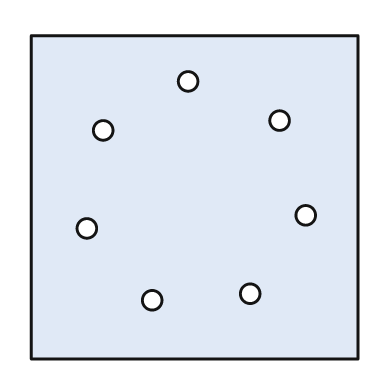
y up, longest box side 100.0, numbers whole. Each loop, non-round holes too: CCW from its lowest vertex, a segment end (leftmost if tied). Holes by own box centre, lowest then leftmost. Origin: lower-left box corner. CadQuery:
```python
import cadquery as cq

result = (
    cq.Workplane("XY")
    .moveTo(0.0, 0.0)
    .lineTo(100.0, 0.0)
    .lineTo(100.0, 99.0)
    .lineTo(0.0, 99.0)
    .close()
    .moveTo(37.0, 18.0)
    .circle(3.0)
    .moveTo(67.0, 20.0)
    .circle(3.0)
    .moveTo(17.0, 40.0)
    .circle(3.0)
    .moveTo(84.0, 44.0)
    .circle(3.0)
    .moveTo(22.0, 70.0)
    .circle(3.0)
    .moveTo(76.0, 73.0)
    .circle(3.0)
    .moveTo(48.0, 85.0)
    .circle(3.0)
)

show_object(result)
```